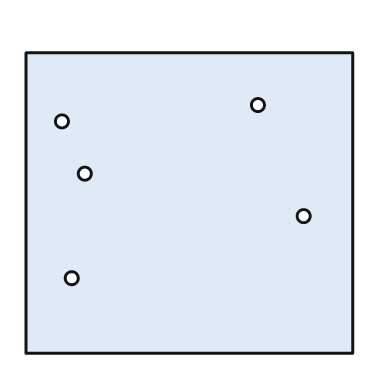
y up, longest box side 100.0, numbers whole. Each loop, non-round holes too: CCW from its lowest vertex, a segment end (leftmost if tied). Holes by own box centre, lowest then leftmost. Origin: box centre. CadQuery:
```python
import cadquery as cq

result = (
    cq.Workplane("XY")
    .moveTo(-50.0, -46.0)
    .lineTo(50.0, -46.0)
    .lineTo(50.0, 46.0)
    .lineTo(-50.0, 46.0)
    .close()
    .moveTo(-36.0, -23.0)
    .circle(2.0)
    .moveTo(35.0, -4.0)
    .circle(2.0)
    .moveTo(-32.0, 9.0)
    .circle(2.0)
    .moveTo(-39.0, 25.0)
    .circle(2.0)
    .moveTo(21.0, 30.0)
    .circle(2.0)
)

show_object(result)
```